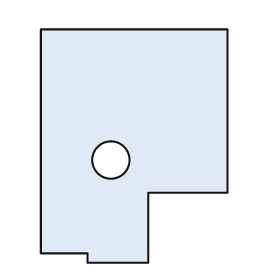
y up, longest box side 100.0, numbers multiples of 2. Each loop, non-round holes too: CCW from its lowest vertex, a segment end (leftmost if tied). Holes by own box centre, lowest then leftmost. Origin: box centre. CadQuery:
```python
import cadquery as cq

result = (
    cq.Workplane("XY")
    .moveTo(-20.0, -50.0)
    .lineTo(6.0, -50.0)
    .lineTo(6.0, -20.0)
    .lineTo(40.0, -20.0)
    .lineTo(40.0, 50.0)
    .lineTo(-40.0, 50.0)
    .lineTo(-40.0, -46.0)
    .lineTo(-20.0, -46.0)
    .close()
    .moveTo(-10.0, -6.0)
    .circle(8.0)
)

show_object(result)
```